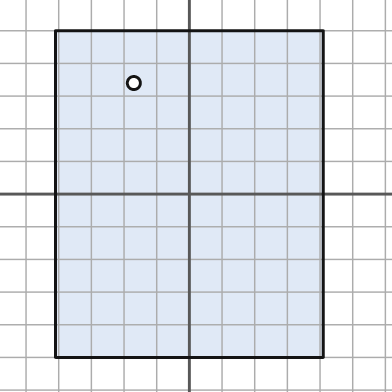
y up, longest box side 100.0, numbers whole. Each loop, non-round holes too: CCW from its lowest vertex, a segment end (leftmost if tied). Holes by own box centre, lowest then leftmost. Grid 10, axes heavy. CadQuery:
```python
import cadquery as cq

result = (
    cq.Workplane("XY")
    .moveTo(-41.0, -50.0)
    .lineTo(41.0, -50.0)
    .lineTo(41.0, 50.0)
    .lineTo(-41.0, 50.0)
    .close()
    .moveTo(-17.0, 34.0)
    .circle(2.0)
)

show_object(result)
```